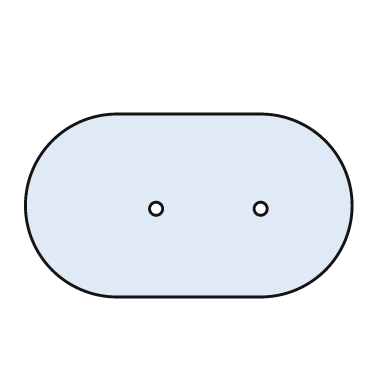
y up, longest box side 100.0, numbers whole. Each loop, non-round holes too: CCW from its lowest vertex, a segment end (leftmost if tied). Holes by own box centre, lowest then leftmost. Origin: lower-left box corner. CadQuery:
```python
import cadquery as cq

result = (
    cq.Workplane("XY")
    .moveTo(28.0, 0.0)
    .lineTo(72.0, 0.0)
    .threePointArc((100.0, 28.0), (72.0, 56.0))
    .lineTo(28.0, 56.0)
    .threePointArc((0.0, 28.0), (28.0, 0.0))
    .close()
    .moveTo(40.0, 27.0)
    .circle(2.0)
    .moveTo(72.0, 27.0)
    .circle(2.0)
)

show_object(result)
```